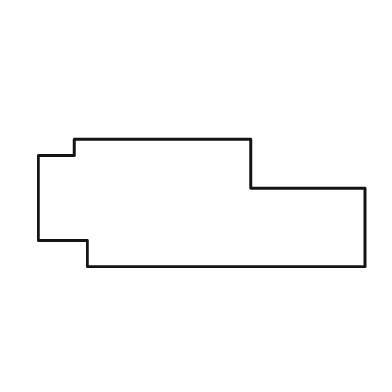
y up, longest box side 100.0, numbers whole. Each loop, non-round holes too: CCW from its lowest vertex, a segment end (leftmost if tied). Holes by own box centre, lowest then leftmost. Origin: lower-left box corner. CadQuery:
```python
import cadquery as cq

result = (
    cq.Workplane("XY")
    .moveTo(15.0, 0.0)
    .lineTo(100.0, 0.0)
    .lineTo(100.0, 24.0)
    .lineTo(65.0, 24.0)
    .lineTo(65.0, 39.0)
    .lineTo(11.0, 39.0)
    .lineTo(11.0, 34.0)
    .lineTo(0.0, 34.0)
    .lineTo(0.0, 8.0)
    .lineTo(15.0, 8.0)
    .close()
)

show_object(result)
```